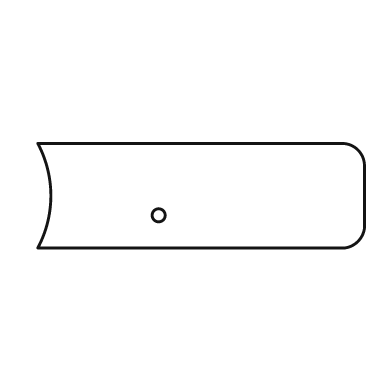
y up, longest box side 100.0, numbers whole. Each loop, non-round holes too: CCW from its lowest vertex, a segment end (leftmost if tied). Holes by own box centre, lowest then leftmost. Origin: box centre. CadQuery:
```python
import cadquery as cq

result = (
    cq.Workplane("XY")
    .moveTo(-50.0, -16.0)
    .lineTo(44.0, -16.0)
    .threePointArc((48.0, -14.0), (50.0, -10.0))
    .lineTo(50.0, 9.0)
    .threePointArc((48.0, 14.0), (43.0, 16.0))
    .lineTo(-50.0, 16.0)
    .threePointArc((-46.0, 0.0), (-50.0, -16.0))
    .close()
    .moveTo(-13.0, -6.0)
    .circle(2.0)
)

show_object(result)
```